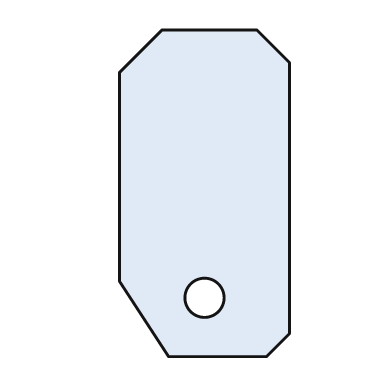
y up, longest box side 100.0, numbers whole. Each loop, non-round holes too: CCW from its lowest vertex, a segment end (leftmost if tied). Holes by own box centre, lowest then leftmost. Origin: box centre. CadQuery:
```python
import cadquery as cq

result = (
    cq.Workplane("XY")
    .moveTo(-11.0, -50.0)
    .lineTo(19.0, -50.0)
    .lineTo(26.0, -43.0)
    .lineTo(26.0, 40.0)
    .lineTo(16.0, 50.0)
    .lineTo(-13.0, 50.0)
    .lineTo(-26.0, 37.0)
    .lineTo(-26.0, -27.0)
    .close()
    .moveTo(0.0, -32.0)
    .circle(6.0)
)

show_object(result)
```